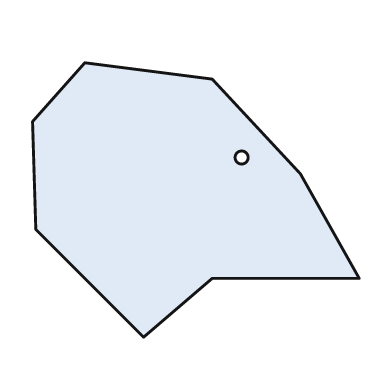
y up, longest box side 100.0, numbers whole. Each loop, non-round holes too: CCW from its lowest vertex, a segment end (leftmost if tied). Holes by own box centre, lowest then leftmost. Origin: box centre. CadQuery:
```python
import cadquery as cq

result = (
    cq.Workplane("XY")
    .moveTo(-16.0, -42.0)
    .lineTo(5.0, -24.0)
    .lineTo(50.0, -24.0)
    .lineTo(32.0, 8.0)
    .lineTo(5.0, 37.0)
    .lineTo(-34.0, 42.0)
    .lineTo(-50.0, 24.0)
    .lineTo(-49.0, -9.0)
    .close()
    .moveTo(14.0, 13.0)
    .circle(2.0)
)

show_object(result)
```